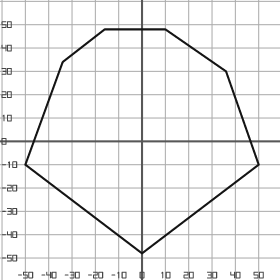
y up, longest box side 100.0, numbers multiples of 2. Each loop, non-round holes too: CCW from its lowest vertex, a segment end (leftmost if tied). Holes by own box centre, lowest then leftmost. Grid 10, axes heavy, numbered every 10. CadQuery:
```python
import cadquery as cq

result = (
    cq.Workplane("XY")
    .moveTo(0.0, -48.0)
    .lineTo(50.0, -10.0)
    .lineTo(36.0, 30.0)
    .lineTo(10.0, 48.0)
    .lineTo(-16.0, 48.0)
    .lineTo(-34.0, 34.0)
    .lineTo(-50.0, -10.0)
    .close()
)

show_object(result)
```